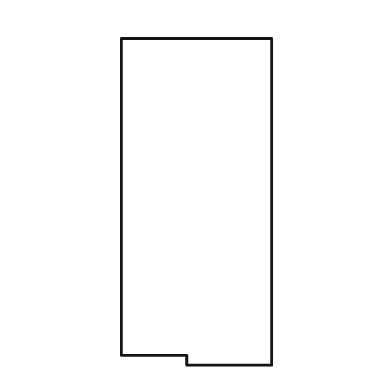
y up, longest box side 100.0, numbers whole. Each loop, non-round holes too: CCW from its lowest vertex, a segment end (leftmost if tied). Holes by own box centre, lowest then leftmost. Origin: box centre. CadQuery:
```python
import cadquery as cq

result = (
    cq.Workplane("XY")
    .moveTo(-3.0, -50.0)
    .lineTo(23.0, -50.0)
    .lineTo(23.0, 50.0)
    .lineTo(-23.0, 50.0)
    .lineTo(-23.0, -47.0)
    .lineTo(-3.0, -47.0)
    .close()
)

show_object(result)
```